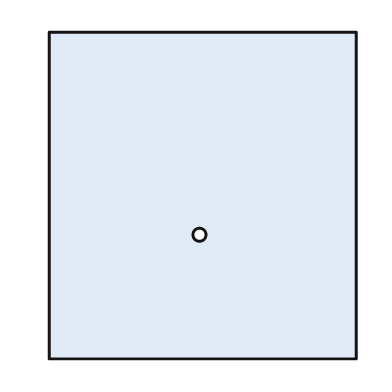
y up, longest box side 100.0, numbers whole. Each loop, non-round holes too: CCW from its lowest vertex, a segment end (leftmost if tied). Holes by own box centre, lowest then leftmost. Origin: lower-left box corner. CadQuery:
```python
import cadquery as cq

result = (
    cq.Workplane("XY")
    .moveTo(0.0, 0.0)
    .lineTo(94.0, 0.0)
    .lineTo(94.0, 100.0)
    .lineTo(0.0, 100.0)
    .close()
    .moveTo(46.0, 38.0)
    .circle(2.0)
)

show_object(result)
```